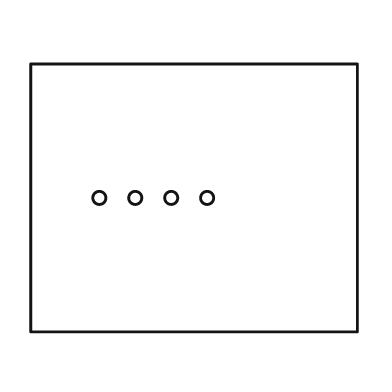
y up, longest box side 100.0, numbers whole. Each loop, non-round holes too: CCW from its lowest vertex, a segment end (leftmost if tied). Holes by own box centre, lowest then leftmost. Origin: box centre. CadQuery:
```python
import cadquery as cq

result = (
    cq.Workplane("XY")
    .moveTo(-50.0, -41.0)
    .lineTo(50.0, -41.0)
    .lineTo(50.0, 41.0)
    .lineTo(-50.0, 41.0)
    .close()
    .moveTo(-29.0, 0.0)
    .circle(2.0)
    .moveTo(-18.0, 0.0)
    .circle(2.0)
    .moveTo(-7.0, 0.0)
    .circle(2.0)
    .moveTo(4.0, 0.0)
    .circle(2.0)
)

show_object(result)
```